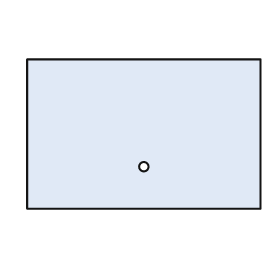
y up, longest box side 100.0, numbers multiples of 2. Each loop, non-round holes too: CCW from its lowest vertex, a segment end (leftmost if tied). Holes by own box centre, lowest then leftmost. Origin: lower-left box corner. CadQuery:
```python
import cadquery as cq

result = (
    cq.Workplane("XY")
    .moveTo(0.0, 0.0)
    .lineTo(100.0, 0.0)
    .lineTo(100.0, 64.0)
    .lineTo(0.0, 64.0)
    .close()
    .moveTo(50.0, 18.0)
    .circle(2.0)
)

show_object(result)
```